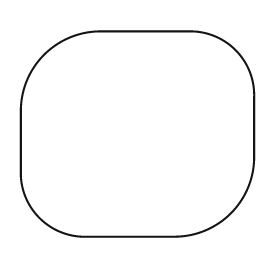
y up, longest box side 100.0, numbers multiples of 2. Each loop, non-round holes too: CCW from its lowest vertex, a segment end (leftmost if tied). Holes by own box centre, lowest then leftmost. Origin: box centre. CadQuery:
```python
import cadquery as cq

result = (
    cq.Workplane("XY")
    .moveTo(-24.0, -44.0)
    .lineTo(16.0, -44.0)
    .threePointArc((40.0, -34.0), (50.0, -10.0))
    .lineTo(50.0, 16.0)
    .threePointArc((42.0, 36.0), (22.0, 44.0))
    .lineTo(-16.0, 44.0)
    .threePointArc((-40.0, 34.0), (-50.0, 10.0))
    .lineTo(-50.0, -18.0)
    .threePointArc((-42.0, -36.0), (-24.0, -44.0))
    .close()
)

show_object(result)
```